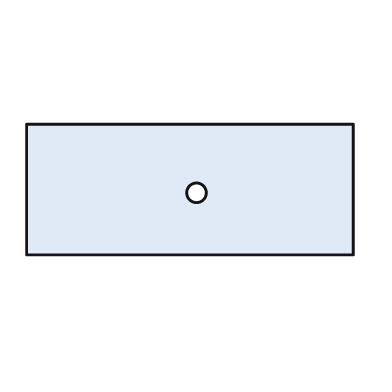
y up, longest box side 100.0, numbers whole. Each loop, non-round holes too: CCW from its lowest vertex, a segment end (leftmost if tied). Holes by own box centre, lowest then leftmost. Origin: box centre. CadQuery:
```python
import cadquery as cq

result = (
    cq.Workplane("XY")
    .moveTo(-50.0, -20.0)
    .lineTo(50.0, -20.0)
    .lineTo(50.0, 20.0)
    .lineTo(-50.0, 20.0)
    .close()
    .moveTo(2.0, -1.0)
    .circle(3.0)
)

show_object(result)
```